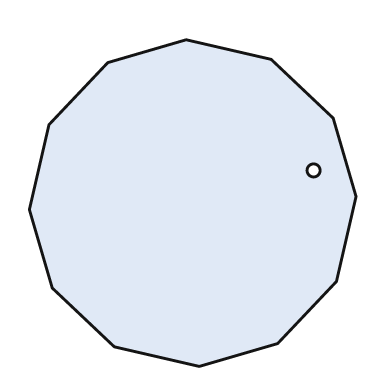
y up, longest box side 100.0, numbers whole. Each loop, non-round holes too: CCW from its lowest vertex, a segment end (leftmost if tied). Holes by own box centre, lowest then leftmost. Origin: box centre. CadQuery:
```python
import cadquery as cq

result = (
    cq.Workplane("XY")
    .moveTo(2.0, -50.0)
    .lineTo(26.0, -43.0)
    .lineTo(44.0, -24.0)
    .lineTo(50.0, 2.0)
    .lineTo(43.0, 26.0)
    .lineTo(24.0, 44.0)
    .lineTo(-2.0, 50.0)
    .lineTo(-26.0, 43.0)
    .lineTo(-44.0, 24.0)
    .lineTo(-50.0, -2.0)
    .lineTo(-43.0, -26.0)
    .lineTo(-24.0, -44.0)
    .close()
    .moveTo(37.0, 10.0)
    .circle(2.0)
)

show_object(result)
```